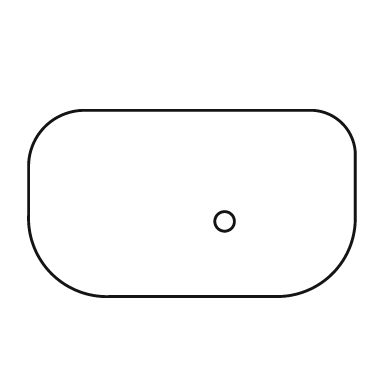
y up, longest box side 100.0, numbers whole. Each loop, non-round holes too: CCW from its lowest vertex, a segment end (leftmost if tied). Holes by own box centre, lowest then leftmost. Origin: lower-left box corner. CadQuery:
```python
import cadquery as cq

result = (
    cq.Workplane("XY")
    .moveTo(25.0, 0.0)
    .lineTo(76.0, 0.0)
    .threePointArc((93.0, 7.0), (100.0, 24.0))
    .lineTo(100.0, 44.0)
    .threePointArc((96.0, 53.0), (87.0, 57.0))
    .lineTo(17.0, 57.0)
    .threePointArc((5.0, 52.0), (0.0, 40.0))
    .lineTo(0.0, 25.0)
    .threePointArc((7.0, 7.0), (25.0, 0.0))
    .close()
    .moveTo(60.0, 23.0)
    .circle(3.0)
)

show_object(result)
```